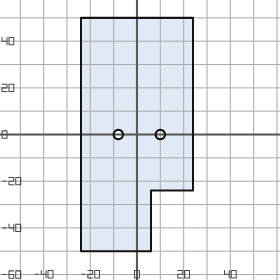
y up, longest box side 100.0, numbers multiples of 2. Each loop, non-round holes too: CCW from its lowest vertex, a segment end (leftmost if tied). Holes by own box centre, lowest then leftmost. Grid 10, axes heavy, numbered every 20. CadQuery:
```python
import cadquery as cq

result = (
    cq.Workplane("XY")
    .moveTo(-24.0, -50.0)
    .lineTo(6.0, -50.0)
    .lineTo(6.0, -24.0)
    .lineTo(24.0, -24.0)
    .lineTo(24.0, 50.0)
    .lineTo(-24.0, 50.0)
    .close()
    .moveTo(-8.0, 0.0)
    .circle(2.0)
    .moveTo(10.0, 0.0)
    .circle(2.0)
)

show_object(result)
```